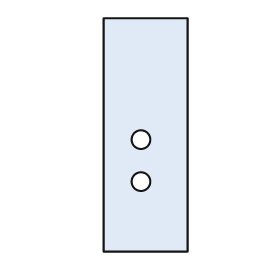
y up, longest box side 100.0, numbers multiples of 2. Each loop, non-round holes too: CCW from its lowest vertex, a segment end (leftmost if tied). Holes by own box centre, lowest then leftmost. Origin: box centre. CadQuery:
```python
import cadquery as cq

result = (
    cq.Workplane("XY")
    .moveTo(-18.0, -50.0)
    .lineTo(18.0, -50.0)
    .lineTo(18.0, 50.0)
    .lineTo(-18.0, 50.0)
    .close()
    .moveTo(-2.0, -20.0)
    .circle(4.0)
    .moveTo(-2.0, -2.0)
    .circle(4.0)
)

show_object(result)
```